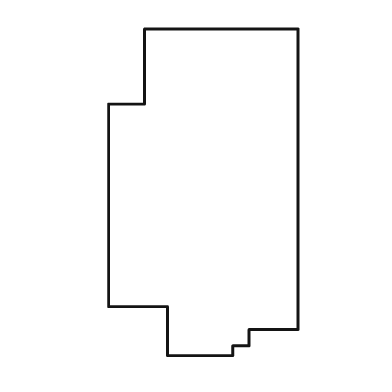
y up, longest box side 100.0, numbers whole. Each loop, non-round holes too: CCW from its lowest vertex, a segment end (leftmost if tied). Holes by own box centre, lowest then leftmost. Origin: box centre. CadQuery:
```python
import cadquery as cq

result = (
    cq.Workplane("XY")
    .moveTo(-11.0, -50.0)
    .lineTo(9.0, -50.0)
    .lineTo(9.0, -47.0)
    .lineTo(14.0, -47.0)
    .lineTo(14.0, -42.0)
    .lineTo(29.0, -42.0)
    .lineTo(29.0, 50.0)
    .lineTo(-18.0, 50.0)
    .lineTo(-18.0, 27.0)
    .lineTo(-29.0, 27.0)
    .lineTo(-29.0, -35.0)
    .lineTo(-11.0, -35.0)
    .close()
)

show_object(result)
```